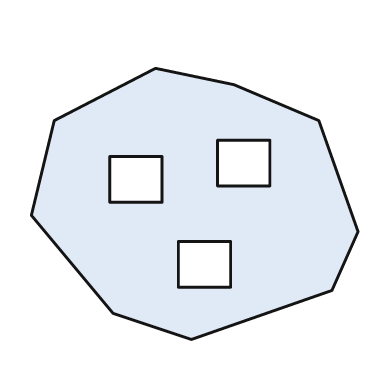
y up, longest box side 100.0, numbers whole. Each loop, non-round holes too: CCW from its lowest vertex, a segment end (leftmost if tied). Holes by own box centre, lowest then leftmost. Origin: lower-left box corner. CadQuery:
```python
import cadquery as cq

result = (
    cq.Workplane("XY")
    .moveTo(49.0, 0.0)
    .lineTo(92.0, 15.0)
    .lineTo(100.0, 33.0)
    .lineTo(88.0, 67.0)
    .lineTo(62.0, 78.0)
    .lineTo(38.0, 83.0)
    .lineTo(7.0, 67.0)
    .lineTo(0.0, 38.0)
    .lineTo(25.0, 8.0)
    .close()
    .moveTo(45.0, 16.0)
    .lineTo(61.0, 16.0)
    .lineTo(61.0, 30.0)
    .lineTo(45.0, 30.0)
    .close()
    .moveTo(24.0, 42.0)
    .lineTo(40.0, 42.0)
    .lineTo(40.0, 56.0)
    .lineTo(24.0, 56.0)
    .close()
    .moveTo(57.0, 47.0)
    .lineTo(73.0, 47.0)
    .lineTo(73.0, 61.0)
    .lineTo(57.0, 61.0)
    .close()
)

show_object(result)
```